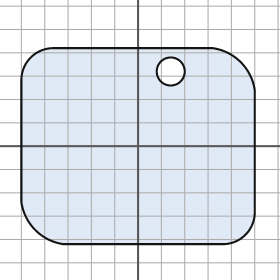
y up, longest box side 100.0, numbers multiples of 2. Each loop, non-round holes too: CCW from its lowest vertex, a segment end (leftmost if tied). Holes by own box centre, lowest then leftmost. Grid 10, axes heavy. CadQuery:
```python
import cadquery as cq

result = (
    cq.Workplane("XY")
    .moveTo(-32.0, -42.0)
    .lineTo(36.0, -42.0)
    .threePointArc((46.0, -38.0), (50.0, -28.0))
    .lineTo(50.0, 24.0)
    .threePointArc((44.0, 36.0), (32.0, 42.0))
    .lineTo(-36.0, 42.0)
    .threePointArc((-46.0, 38.0), (-50.0, 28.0))
    .lineTo(-50.0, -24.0)
    .threePointArc((-44.0, -36.0), (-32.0, -42.0))
    .close()
    .moveTo(14.0, 32.0)
    .circle(6.0)
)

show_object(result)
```